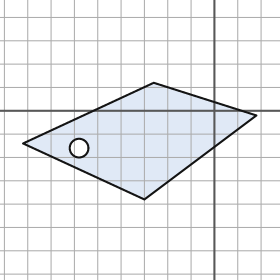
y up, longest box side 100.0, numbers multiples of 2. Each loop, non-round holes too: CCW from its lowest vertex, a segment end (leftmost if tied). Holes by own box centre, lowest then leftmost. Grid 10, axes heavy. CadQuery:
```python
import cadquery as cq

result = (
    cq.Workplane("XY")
    .moveTo(-30.0, -38.0)
    .lineTo(18.0, -2.0)
    .lineTo(-26.0, 12.0)
    .lineTo(-82.0, -14.0)
    .close()
    .moveTo(-58.0, -16.0)
    .circle(4.0)
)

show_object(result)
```